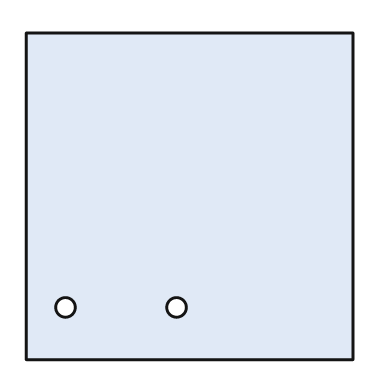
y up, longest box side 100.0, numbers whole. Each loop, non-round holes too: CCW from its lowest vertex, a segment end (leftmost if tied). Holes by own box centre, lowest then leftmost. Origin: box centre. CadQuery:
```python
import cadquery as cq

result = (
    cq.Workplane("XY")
    .moveTo(-50.0, -50.0)
    .lineTo(50.0, -50.0)
    .lineTo(50.0, 50.0)
    .lineTo(-50.0, 50.0)
    .close()
    .moveTo(-38.0, -34.0)
    .circle(3.0)
    .moveTo(-4.0, -34.0)
    .circle(3.0)
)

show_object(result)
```